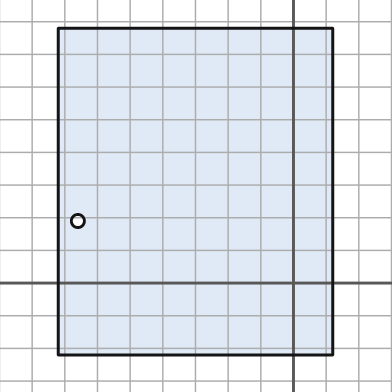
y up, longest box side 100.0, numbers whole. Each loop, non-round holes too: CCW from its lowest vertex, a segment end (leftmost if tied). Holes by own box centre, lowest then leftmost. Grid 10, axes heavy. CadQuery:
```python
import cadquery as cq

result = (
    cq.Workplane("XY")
    .moveTo(-72.0, -22.0)
    .lineTo(12.0, -22.0)
    .lineTo(12.0, 78.0)
    .lineTo(-72.0, 78.0)
    .close()
    .moveTo(-66.0, 19.0)
    .circle(2.0)
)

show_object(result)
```